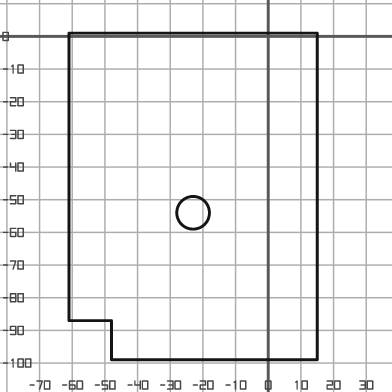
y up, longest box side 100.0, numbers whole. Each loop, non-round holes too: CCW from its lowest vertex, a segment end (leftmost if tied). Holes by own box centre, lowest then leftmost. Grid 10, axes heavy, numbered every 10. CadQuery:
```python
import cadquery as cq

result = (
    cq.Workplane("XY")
    .moveTo(-48.0, -99.0)
    .lineTo(15.0, -99.0)
    .lineTo(15.0, 1.0)
    .lineTo(-61.0, 1.0)
    .lineTo(-61.0, -87.0)
    .lineTo(-48.0, -87.0)
    .close()
    .moveTo(-23.0, -54.0)
    .circle(5.0)
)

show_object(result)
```